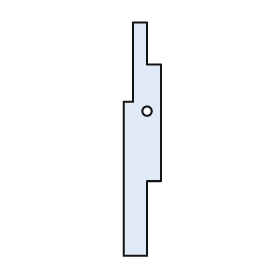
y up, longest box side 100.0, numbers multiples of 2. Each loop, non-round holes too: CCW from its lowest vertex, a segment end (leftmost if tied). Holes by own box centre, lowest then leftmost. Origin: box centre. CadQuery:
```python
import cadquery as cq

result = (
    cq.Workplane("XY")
    .moveTo(-8.0, -50.0)
    .lineTo(2.0, -50.0)
    .lineTo(2.0, -18.0)
    .lineTo(8.0, -18.0)
    .lineTo(8.0, 32.0)
    .lineTo(2.0, 32.0)
    .lineTo(2.0, 50.0)
    .lineTo(-4.0, 50.0)
    .lineTo(-4.0, 16.0)
    .lineTo(-8.0, 16.0)
    .close()
    .moveTo(2.0, 12.0)
    .circle(2.0)
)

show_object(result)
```